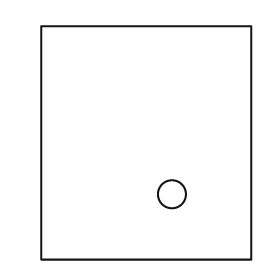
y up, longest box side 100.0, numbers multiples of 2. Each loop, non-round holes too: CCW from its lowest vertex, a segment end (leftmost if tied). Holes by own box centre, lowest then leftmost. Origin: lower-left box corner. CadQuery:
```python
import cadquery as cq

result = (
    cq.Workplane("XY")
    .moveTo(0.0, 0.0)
    .lineTo(90.0, 0.0)
    .lineTo(90.0, 100.0)
    .lineTo(0.0, 100.0)
    .close()
    .moveTo(56.0, 28.0)
    .circle(6.0)
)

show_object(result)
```